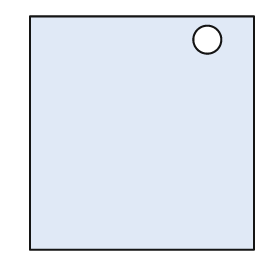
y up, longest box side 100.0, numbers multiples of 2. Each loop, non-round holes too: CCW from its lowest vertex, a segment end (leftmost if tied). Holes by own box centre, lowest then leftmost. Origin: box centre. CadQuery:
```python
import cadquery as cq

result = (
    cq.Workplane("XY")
    .moveTo(-48.0, -50.0)
    .lineTo(48.0, -50.0)
    .lineTo(48.0, 50.0)
    .lineTo(-48.0, 50.0)
    .close()
    .moveTo(28.0, 40.0)
    .circle(6.0)
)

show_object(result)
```